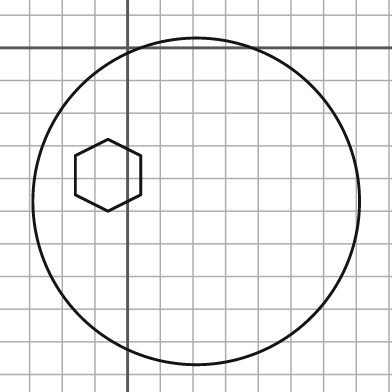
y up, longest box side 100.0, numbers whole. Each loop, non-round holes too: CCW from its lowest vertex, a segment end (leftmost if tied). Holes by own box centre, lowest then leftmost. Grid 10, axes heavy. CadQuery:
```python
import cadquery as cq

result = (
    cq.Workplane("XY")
    .moveTo(21.0, -47.0)
    .circle(50.0)
    .moveTo(-6.0, -50.0)
    .lineTo(4.0, -45.0)
    .lineTo(4.0, -33.0)
    .lineTo(-6.0, -28.0)
    .lineTo(-16.0, -33.0)
    .lineTo(-16.0, -45.0)
    .close()
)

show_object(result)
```